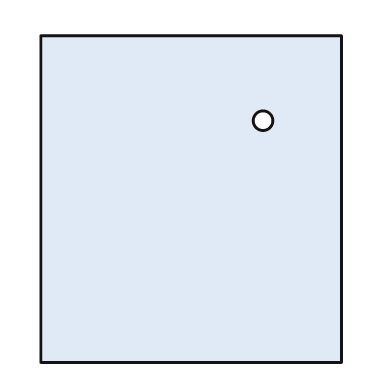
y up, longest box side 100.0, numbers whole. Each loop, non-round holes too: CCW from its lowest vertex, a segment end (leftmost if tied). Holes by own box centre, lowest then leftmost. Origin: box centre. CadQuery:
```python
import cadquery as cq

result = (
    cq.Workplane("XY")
    .moveTo(-46.0, -50.0)
    .lineTo(46.0, -50.0)
    .lineTo(46.0, 50.0)
    .lineTo(-46.0, 50.0)
    .close()
    .moveTo(22.0, 24.0)
    .circle(3.0)
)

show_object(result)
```